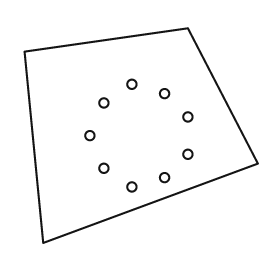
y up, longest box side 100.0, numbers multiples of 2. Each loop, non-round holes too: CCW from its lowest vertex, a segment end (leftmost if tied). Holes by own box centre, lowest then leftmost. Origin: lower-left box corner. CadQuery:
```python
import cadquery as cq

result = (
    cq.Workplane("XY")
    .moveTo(8.0, 0.0)
    .lineTo(100.0, 34.0)
    .lineTo(70.0, 92.0)
    .lineTo(0.0, 82.0)
    .close()
    .moveTo(46.0, 24.0)
    .circle(2.0)
    .moveTo(60.0, 28.0)
    .circle(2.0)
    .moveTo(34.0, 32.0)
    .circle(2.0)
    .moveTo(70.0, 38.0)
    .circle(2.0)
    .moveTo(28.0, 46.0)
    .circle(2.0)
    .moveTo(70.0, 54.0)
    .circle(2.0)
    .moveTo(34.0, 60.0)
    .circle(2.0)
    .moveTo(60.0, 64.0)
    .circle(2.0)
    .moveTo(46.0, 68.0)
    .circle(2.0)
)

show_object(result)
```